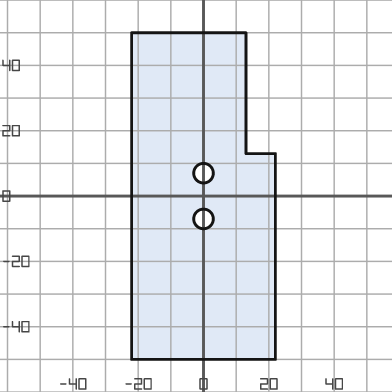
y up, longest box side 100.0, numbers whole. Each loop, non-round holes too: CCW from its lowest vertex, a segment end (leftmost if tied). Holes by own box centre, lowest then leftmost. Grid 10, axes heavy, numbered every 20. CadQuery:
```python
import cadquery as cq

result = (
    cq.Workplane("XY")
    .moveTo(-22.0, -50.0)
    .lineTo(22.0, -50.0)
    .lineTo(22.0, 13.0)
    .lineTo(13.0, 13.0)
    .lineTo(13.0, 50.0)
    .lineTo(-22.0, 50.0)
    .close()
    .moveTo(0.0, -7.0)
    .circle(3.0)
    .moveTo(0.0, 7.0)
    .circle(3.0)
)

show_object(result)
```